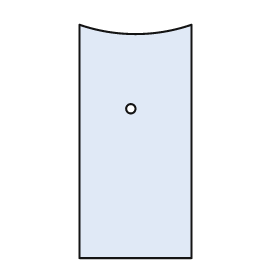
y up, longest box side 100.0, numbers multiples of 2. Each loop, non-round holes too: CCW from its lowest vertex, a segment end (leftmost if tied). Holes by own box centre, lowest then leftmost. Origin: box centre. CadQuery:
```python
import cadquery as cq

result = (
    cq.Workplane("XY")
    .moveTo(-24.0, -50.0)
    .lineTo(24.0, -50.0)
    .lineTo(24.0, 50.0)
    .threePointArc((0.0, 46.0), (-24.0, 50.0))
    .close()
    .moveTo(-2.0, 14.0)
    .circle(2.0)
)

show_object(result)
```